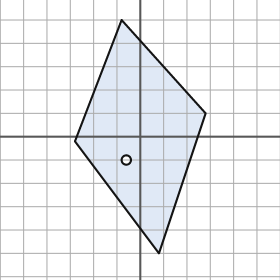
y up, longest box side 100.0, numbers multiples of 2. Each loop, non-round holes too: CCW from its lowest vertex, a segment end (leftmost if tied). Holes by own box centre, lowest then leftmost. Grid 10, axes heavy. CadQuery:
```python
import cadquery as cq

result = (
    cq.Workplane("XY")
    .moveTo(8.0, -50.0)
    .lineTo(28.0, 10.0)
    .lineTo(-8.0, 50.0)
    .lineTo(-28.0, -2.0)
    .close()
    .moveTo(-6.0, -10.0)
    .circle(2.0)
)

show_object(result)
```